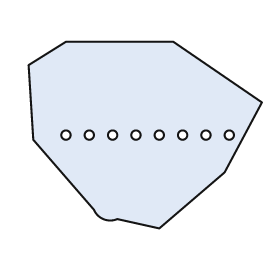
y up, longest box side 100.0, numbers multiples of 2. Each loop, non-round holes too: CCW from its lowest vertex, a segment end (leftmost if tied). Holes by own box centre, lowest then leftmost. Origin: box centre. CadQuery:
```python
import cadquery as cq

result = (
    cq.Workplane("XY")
    .moveTo(6.0, -40.0)
    .lineTo(34.0, -16.0)
    .lineTo(50.0, 14.0)
    .lineTo(12.0, 40.0)
    .lineTo(-34.0, 40.0)
    .lineTo(-50.0, 30.0)
    .lineTo(-48.0, -2.0)
    .lineTo(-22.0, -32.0)
    .threePointArc((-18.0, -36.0), (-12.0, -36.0))
    .close()
    .moveTo(-34.0, 0.0)
    .circle(2.0)
    .moveTo(-24.0, 0.0)
    .circle(2.0)
    .moveTo(-14.0, 0.0)
    .circle(2.0)
    .moveTo(-4.0, 0.0)
    .circle(2.0)
    .moveTo(6.0, 0.0)
    .circle(2.0)
    .moveTo(16.0, 0.0)
    .circle(2.0)
    .moveTo(26.0, 0.0)
    .circle(2.0)
    .moveTo(36.0, 0.0)
    .circle(2.0)
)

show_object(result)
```